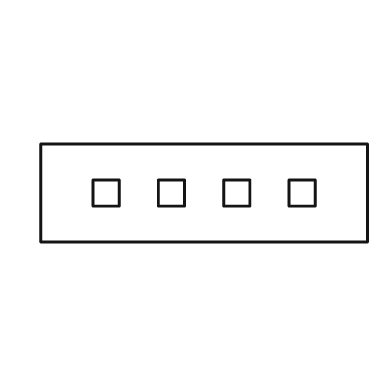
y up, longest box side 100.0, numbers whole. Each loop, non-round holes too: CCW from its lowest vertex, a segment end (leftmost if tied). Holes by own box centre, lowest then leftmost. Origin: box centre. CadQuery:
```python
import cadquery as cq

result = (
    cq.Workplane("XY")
    .moveTo(-50.0, -15.0)
    .lineTo(50.0, -15.0)
    .lineTo(50.0, 15.0)
    .lineTo(-50.0, 15.0)
    .close()
    .moveTo(-34.0, -4.0)
    .lineTo(-26.0, -4.0)
    .lineTo(-26.0, 4.0)
    .lineTo(-34.0, 4.0)
    .close()
    .moveTo(-14.0, -4.0)
    .lineTo(-6.0, -4.0)
    .lineTo(-6.0, 4.0)
    .lineTo(-14.0, 4.0)
    .close()
    .moveTo(6.0, -4.0)
    .lineTo(14.0, -4.0)
    .lineTo(14.0, 4.0)
    .lineTo(6.0, 4.0)
    .close()
    .moveTo(26.0, -4.0)
    .lineTo(34.0, -4.0)
    .lineTo(34.0, 4.0)
    .lineTo(26.0, 4.0)
    .close()
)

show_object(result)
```